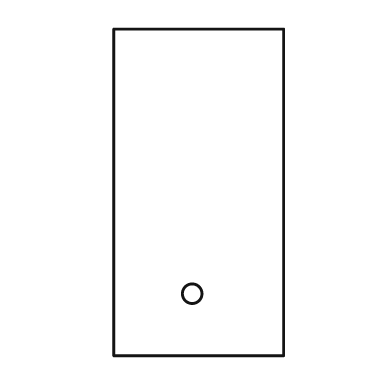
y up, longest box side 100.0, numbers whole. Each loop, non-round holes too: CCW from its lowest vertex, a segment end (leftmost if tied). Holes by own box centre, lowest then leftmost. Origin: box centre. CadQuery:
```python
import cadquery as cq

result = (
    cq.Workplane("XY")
    .moveTo(-26.0, -50.0)
    .lineTo(26.0, -50.0)
    .lineTo(26.0, 50.0)
    .lineTo(-26.0, 50.0)
    .close()
    .moveTo(-2.0, -31.0)
    .circle(3.0)
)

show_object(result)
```